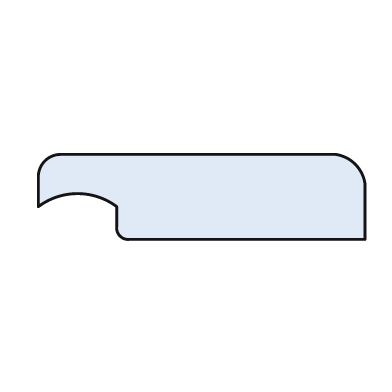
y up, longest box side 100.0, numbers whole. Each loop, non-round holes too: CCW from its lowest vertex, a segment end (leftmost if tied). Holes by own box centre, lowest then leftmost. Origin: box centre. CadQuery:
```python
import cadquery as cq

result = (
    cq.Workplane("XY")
    .moveTo(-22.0, -13.0)
    .lineTo(50.0, -13.0)
    .lineTo(50.0, 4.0)
    .threePointArc((47.0, 10.0), (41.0, 13.0))
    .lineTo(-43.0, 13.0)
    .threePointArc((-48.0, 11.0), (-50.0, 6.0))
    .lineTo(-50.0, -3.0)
    .threePointArc((-38.0, 1.0), (-26.0, -3.0))
    .lineTo(-26.0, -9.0)
    .threePointArc((-25.0, -12.0), (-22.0, -13.0))
    .close()
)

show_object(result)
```